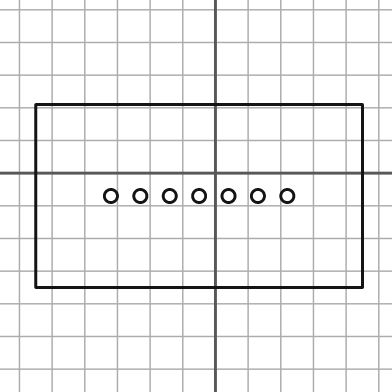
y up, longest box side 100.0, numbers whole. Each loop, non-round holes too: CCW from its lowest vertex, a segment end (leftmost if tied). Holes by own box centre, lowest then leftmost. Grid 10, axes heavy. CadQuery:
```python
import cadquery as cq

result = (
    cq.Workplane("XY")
    .moveTo(-55.0, -35.0)
    .lineTo(45.0, -35.0)
    .lineTo(45.0, 21.0)
    .lineTo(-55.0, 21.0)
    .close()
    .moveTo(-32.0, -7.0)
    .circle(2.0)
    .moveTo(-23.0, -7.0)
    .circle(2.0)
    .moveTo(-14.0, -7.0)
    .circle(2.0)
    .moveTo(-5.0, -7.0)
    .circle(2.0)
    .moveTo(4.0, -7.0)
    .circle(2.0)
    .moveTo(13.0, -7.0)
    .circle(2.0)
    .moveTo(22.0, -7.0)
    .circle(2.0)
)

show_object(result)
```